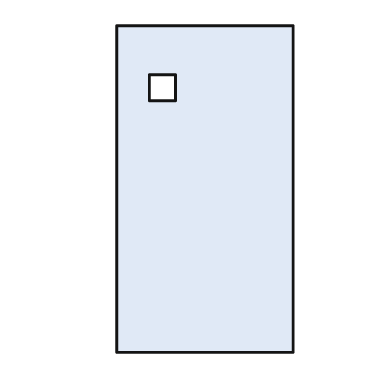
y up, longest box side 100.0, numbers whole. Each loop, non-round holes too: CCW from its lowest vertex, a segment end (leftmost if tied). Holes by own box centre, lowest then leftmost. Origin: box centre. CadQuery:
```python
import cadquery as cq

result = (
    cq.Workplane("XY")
    .moveTo(-27.0, -50.0)
    .lineTo(27.0, -50.0)
    .lineTo(27.0, 50.0)
    .lineTo(-27.0, 50.0)
    .close()
    .moveTo(-17.0, 27.0)
    .lineTo(-9.0, 27.0)
    .lineTo(-9.0, 35.0)
    .lineTo(-17.0, 35.0)
    .close()
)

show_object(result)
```